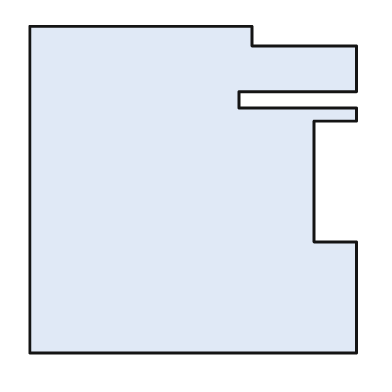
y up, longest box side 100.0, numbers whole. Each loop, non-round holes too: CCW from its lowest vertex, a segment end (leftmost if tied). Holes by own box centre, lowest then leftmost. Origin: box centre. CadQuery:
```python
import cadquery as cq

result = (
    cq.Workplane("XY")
    .moveTo(-50.0, -50.0)
    .lineTo(50.0, -50.0)
    .lineTo(50.0, -16.0)
    .lineTo(37.0, -16.0)
    .lineTo(37.0, 21.0)
    .lineTo(50.0, 21.0)
    .lineTo(50.0, 25.0)
    .lineTo(14.0, 25.0)
    .lineTo(14.0, 30.0)
    .lineTo(50.0, 30.0)
    .lineTo(50.0, 44.0)
    .lineTo(18.0, 44.0)
    .lineTo(18.0, 50.0)
    .lineTo(-50.0, 50.0)
    .close()
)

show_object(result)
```